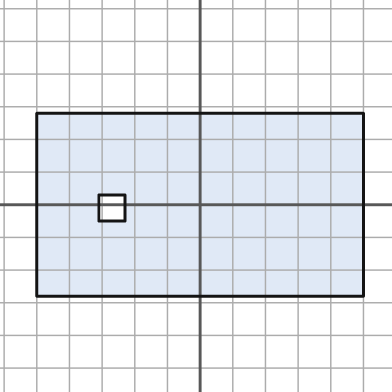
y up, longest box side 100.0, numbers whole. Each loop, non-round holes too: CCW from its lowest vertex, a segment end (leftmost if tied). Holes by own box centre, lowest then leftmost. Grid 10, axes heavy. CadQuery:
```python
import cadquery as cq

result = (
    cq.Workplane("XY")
    .moveTo(-50.0, -28.0)
    .lineTo(50.0, -28.0)
    .lineTo(50.0, 28.0)
    .lineTo(-50.0, 28.0)
    .close()
    .moveTo(-31.0, -5.0)
    .lineTo(-23.0, -5.0)
    .lineTo(-23.0, 3.0)
    .lineTo(-31.0, 3.0)
    .close()
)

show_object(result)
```